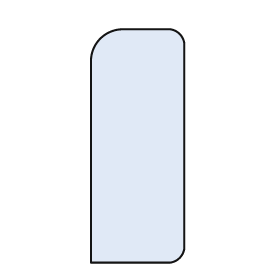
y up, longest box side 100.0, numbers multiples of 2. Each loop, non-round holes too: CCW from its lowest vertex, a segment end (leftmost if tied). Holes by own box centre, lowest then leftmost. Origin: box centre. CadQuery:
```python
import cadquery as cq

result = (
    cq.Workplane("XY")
    .moveTo(-20.0, -50.0)
    .lineTo(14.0, -50.0)
    .threePointArc((18.0, -48.0), (20.0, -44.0))
    .lineTo(20.0, 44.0)
    .threePointArc((18.0, 48.0), (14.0, 50.0))
    .lineTo(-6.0, 50.0)
    .threePointArc((-16.0, 46.0), (-20.0, 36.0))
    .close()
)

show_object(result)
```